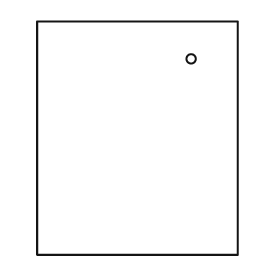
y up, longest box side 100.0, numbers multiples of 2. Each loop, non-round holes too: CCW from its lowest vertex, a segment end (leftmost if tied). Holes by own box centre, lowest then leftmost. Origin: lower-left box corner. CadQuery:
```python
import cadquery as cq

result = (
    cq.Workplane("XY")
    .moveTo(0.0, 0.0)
    .lineTo(86.0, 0.0)
    .lineTo(86.0, 100.0)
    .lineTo(0.0, 100.0)
    .close()
    .moveTo(66.0, 84.0)
    .circle(2.0)
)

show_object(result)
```